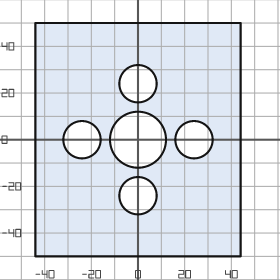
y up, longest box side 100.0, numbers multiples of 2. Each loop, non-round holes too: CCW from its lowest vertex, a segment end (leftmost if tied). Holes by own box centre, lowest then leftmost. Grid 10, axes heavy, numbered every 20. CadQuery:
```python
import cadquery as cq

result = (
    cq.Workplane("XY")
    .moveTo(-44.0, -50.0)
    .lineTo(44.0, -50.0)
    .lineTo(44.0, 50.0)
    .lineTo(-44.0, 50.0)
    .close()
    .moveTo(0.0, -24.0)
    .circle(8.0)
    .moveTo(-24.0, 0.0)
    .circle(8.0)
    .moveTo(0.0, 0.0)
    .circle(12.0)
    .moveTo(24.0, 0.0)
    .circle(8.0)
    .moveTo(0.0, 24.0)
    .circle(8.0)
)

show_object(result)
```